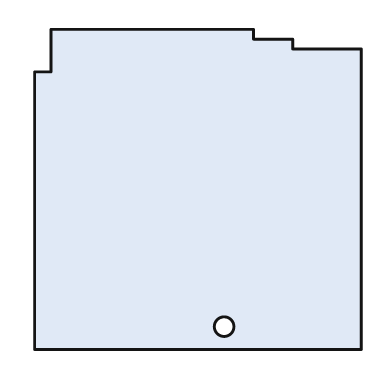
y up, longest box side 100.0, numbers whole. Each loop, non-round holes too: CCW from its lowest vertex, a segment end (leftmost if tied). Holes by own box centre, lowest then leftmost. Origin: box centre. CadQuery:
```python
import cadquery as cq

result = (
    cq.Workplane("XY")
    .moveTo(-50.0, -49.0)
    .lineTo(50.0, -49.0)
    .lineTo(50.0, 43.0)
    .lineTo(29.0, 43.0)
    .lineTo(29.0, 46.0)
    .lineTo(17.0, 46.0)
    .lineTo(17.0, 49.0)
    .lineTo(-45.0, 49.0)
    .lineTo(-45.0, 36.0)
    .lineTo(-50.0, 36.0)
    .close()
    .moveTo(8.0, -42.0)
    .circle(3.0)
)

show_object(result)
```